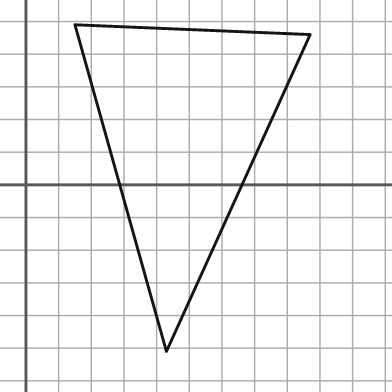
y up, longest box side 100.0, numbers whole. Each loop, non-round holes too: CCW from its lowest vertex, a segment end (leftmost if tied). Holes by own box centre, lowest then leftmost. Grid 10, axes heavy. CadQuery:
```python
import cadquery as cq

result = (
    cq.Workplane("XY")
    .moveTo(43.0, -51.0)
    .lineTo(87.0, 46.0)
    .lineTo(15.0, 49.0)
    .close()
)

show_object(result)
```